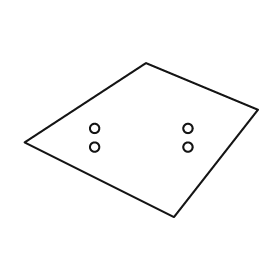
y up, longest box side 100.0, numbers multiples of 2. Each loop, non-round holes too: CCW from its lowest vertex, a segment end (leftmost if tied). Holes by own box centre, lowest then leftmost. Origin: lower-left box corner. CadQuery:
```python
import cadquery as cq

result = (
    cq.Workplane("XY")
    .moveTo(64.0, 0.0)
    .lineTo(100.0, 46.0)
    .lineTo(52.0, 66.0)
    .lineTo(0.0, 32.0)
    .close()
    .moveTo(30.0, 30.0)
    .circle(2.0)
    .moveTo(70.0, 30.0)
    .circle(2.0)
    .moveTo(30.0, 38.0)
    .circle(2.0)
    .moveTo(70.0, 38.0)
    .circle(2.0)
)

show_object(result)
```